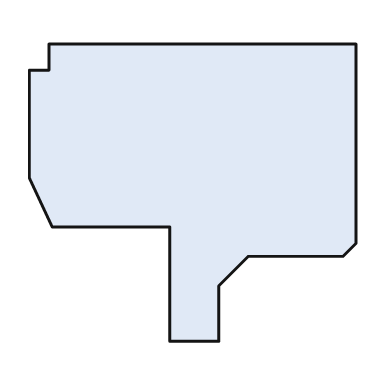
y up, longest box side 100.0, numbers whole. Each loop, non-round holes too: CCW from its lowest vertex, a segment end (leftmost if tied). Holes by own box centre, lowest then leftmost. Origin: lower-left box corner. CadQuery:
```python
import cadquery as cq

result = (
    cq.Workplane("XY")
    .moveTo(43.0, 0.0)
    .lineTo(58.0, 0.0)
    .lineTo(58.0, 17.0)
    .lineTo(67.0, 26.0)
    .lineTo(96.0, 26.0)
    .lineTo(100.0, 30.0)
    .lineTo(100.0, 91.0)
    .lineTo(6.0, 91.0)
    .lineTo(6.0, 83.0)
    .lineTo(0.0, 83.0)
    .lineTo(0.0, 50.0)
    .lineTo(7.0, 35.0)
    .lineTo(43.0, 35.0)
    .close()
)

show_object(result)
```